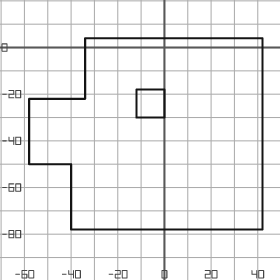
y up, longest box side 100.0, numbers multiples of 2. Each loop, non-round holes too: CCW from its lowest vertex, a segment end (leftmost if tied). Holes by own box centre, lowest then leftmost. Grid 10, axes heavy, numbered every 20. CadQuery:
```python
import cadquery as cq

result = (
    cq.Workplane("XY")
    .moveTo(-40.0, -78.0)
    .lineTo(42.0, -78.0)
    .lineTo(42.0, 4.0)
    .lineTo(-34.0, 4.0)
    .lineTo(-34.0, -22.0)
    .lineTo(-58.0, -22.0)
    .lineTo(-58.0, -50.0)
    .lineTo(-40.0, -50.0)
    .close()
    .moveTo(-12.0, -30.0)
    .lineTo(0.0, -30.0)
    .lineTo(0.0, -18.0)
    .lineTo(-12.0, -18.0)
    .close()
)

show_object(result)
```